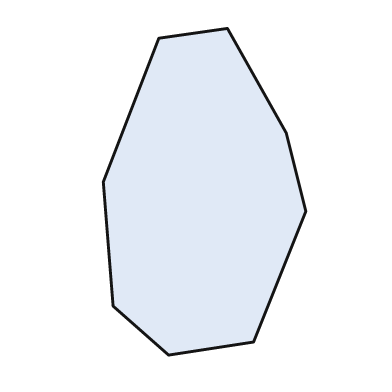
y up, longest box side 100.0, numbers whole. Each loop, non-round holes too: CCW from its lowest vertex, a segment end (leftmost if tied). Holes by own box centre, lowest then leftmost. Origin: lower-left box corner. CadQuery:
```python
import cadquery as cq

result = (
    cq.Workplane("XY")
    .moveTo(20.0, 0.0)
    .lineTo(46.0, 4.0)
    .lineTo(62.0, 44.0)
    .lineTo(56.0, 68.0)
    .lineTo(38.0, 100.0)
    .lineTo(17.0, 97.0)
    .lineTo(0.0, 53.0)
    .lineTo(3.0, 15.0)
    .close()
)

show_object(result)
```